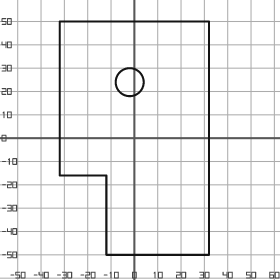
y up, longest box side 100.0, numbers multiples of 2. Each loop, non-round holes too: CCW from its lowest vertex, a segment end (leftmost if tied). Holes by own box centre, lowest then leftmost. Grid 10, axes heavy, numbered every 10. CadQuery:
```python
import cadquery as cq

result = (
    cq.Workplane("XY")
    .moveTo(-12.0, -50.0)
    .lineTo(32.0, -50.0)
    .lineTo(32.0, 50.0)
    .lineTo(-32.0, 50.0)
    .lineTo(-32.0, -16.0)
    .lineTo(-12.0, -16.0)
    .close()
    .moveTo(-2.0, 24.0)
    .circle(6.0)
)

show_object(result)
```